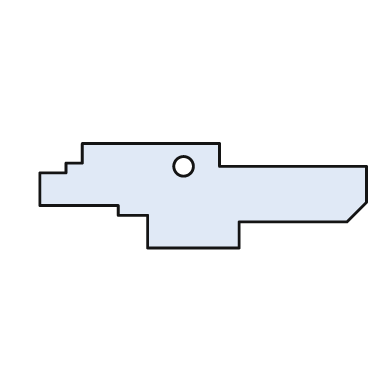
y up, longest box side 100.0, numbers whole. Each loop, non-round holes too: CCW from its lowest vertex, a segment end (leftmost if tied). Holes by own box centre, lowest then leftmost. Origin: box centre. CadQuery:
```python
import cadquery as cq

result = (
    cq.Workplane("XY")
    .moveTo(-17.0, -16.0)
    .lineTo(11.0, -16.0)
    .lineTo(11.0, -8.0)
    .lineTo(44.0, -8.0)
    .lineTo(50.0, -2.0)
    .lineTo(50.0, 9.0)
    .lineTo(5.0, 9.0)
    .lineTo(5.0, 16.0)
    .lineTo(-37.0, 16.0)
    .lineTo(-37.0, 10.0)
    .lineTo(-42.0, 10.0)
    .lineTo(-42.0, 7.0)
    .lineTo(-50.0, 7.0)
    .lineTo(-50.0, -3.0)
    .lineTo(-26.0, -3.0)
    .lineTo(-26.0, -6.0)
    .lineTo(-17.0, -6.0)
    .close()
    .moveTo(-6.0, 9.0)
    .circle(3.0)
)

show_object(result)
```